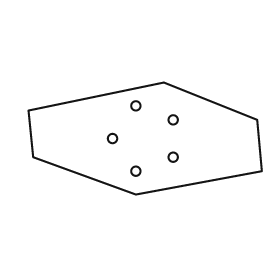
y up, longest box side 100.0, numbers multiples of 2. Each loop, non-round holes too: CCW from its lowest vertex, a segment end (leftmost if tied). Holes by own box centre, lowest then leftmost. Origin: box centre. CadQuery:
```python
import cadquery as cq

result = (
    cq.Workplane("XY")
    .moveTo(-4.0, -24.0)
    .lineTo(50.0, -14.0)
    .lineTo(48.0, 8.0)
    .lineTo(8.0, 24.0)
    .lineTo(-50.0, 12.0)
    .lineTo(-48.0, -8.0)
    .close()
    .moveTo(-4.0, -14.0)
    .circle(2.0)
    .moveTo(12.0, -8.0)
    .circle(2.0)
    .moveTo(-14.0, 0.0)
    .circle(2.0)
    .moveTo(12.0, 8.0)
    .circle(2.0)
    .moveTo(-4.0, 14.0)
    .circle(2.0)
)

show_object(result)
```